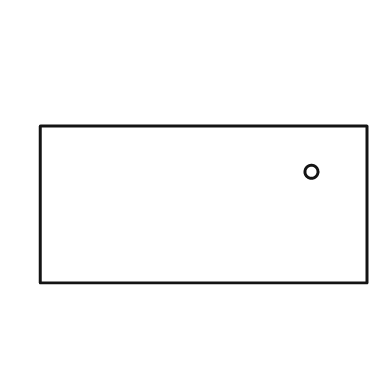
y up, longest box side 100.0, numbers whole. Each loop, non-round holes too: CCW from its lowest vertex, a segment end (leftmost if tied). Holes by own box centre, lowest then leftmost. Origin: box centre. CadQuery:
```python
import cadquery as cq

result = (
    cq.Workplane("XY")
    .moveTo(-50.0, -24.0)
    .lineTo(50.0, -24.0)
    .lineTo(50.0, 24.0)
    .lineTo(-50.0, 24.0)
    .close()
    .moveTo(33.0, 10.0)
    .circle(2.0)
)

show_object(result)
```